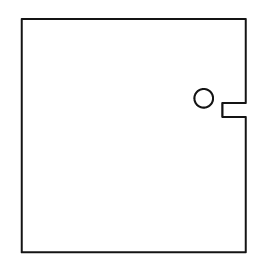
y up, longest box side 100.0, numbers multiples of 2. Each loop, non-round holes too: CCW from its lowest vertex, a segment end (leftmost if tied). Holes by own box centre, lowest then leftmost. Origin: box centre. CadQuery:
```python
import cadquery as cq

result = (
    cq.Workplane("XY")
    .moveTo(-48.0, -50.0)
    .lineTo(48.0, -50.0)
    .lineTo(48.0, 8.0)
    .lineTo(38.0, 8.0)
    .lineTo(38.0, 14.0)
    .lineTo(48.0, 14.0)
    .lineTo(48.0, 50.0)
    .lineTo(-48.0, 50.0)
    .close()
    .moveTo(30.0, 16.0)
    .circle(4.0)
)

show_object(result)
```